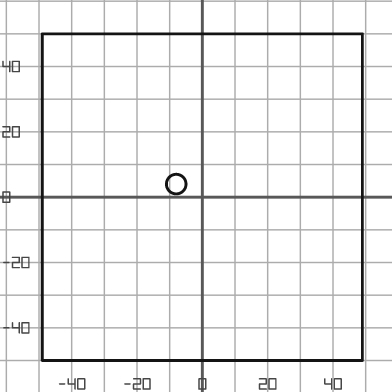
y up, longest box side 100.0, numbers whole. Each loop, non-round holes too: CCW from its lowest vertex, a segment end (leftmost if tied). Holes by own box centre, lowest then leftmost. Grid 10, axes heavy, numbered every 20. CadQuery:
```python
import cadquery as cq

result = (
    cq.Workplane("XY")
    .moveTo(-49.0, -50.0)
    .lineTo(49.0, -50.0)
    .lineTo(49.0, 50.0)
    .lineTo(-49.0, 50.0)
    .close()
    .moveTo(-8.0, 4.0)
    .circle(3.0)
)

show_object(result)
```